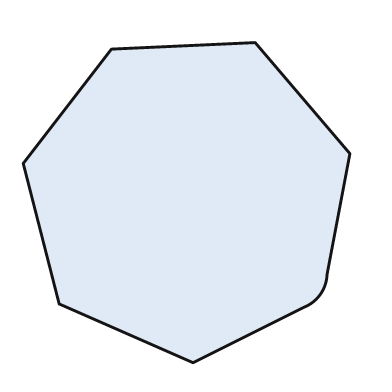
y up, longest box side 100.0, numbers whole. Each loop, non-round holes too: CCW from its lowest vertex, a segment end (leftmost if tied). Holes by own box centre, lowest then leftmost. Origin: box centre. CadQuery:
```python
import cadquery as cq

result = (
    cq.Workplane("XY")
    .moveTo(2.0, -49.0)
    .lineTo(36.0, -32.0)
    .threePointArc((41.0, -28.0), (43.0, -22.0))
    .lineTo(50.0, 15.0)
    .lineTo(21.0, 49.0)
    .lineTo(-23.0, 47.0)
    .lineTo(-50.0, 12.0)
    .lineTo(-39.0, -31.0)
    .close()
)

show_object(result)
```